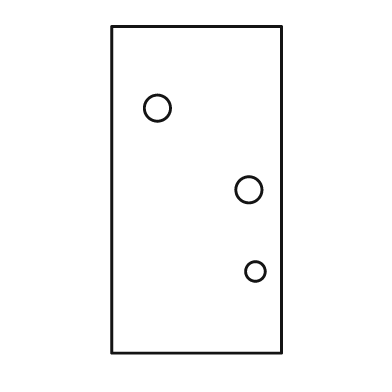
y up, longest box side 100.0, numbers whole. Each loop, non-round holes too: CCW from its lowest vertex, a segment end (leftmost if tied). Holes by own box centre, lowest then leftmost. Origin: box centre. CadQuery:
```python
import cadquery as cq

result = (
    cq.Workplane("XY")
    .moveTo(-26.0, -50.0)
    .lineTo(26.0, -50.0)
    .lineTo(26.0, 50.0)
    .lineTo(-26.0, 50.0)
    .close()
    .moveTo(18.0, -25.0)
    .circle(3.0)
    .moveTo(16.0, 0.0)
    .circle(4.0)
    .moveTo(-12.0, 25.0)
    .circle(4.0)
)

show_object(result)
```